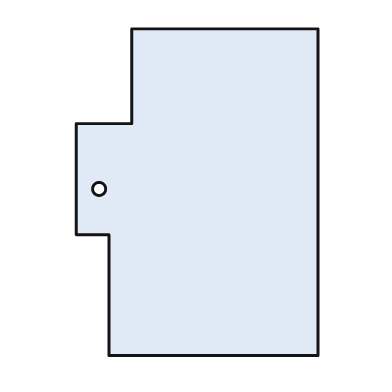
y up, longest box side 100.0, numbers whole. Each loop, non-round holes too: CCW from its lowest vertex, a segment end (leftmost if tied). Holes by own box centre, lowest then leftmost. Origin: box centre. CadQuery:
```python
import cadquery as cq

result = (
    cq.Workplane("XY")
    .moveTo(-27.0, -50.0)
    .lineTo(37.0, -50.0)
    .lineTo(37.0, 50.0)
    .lineTo(-20.0, 50.0)
    .lineTo(-20.0, 21.0)
    .lineTo(-37.0, 21.0)
    .lineTo(-37.0, -13.0)
    .lineTo(-27.0, -13.0)
    .close()
    .moveTo(-30.0, 1.0)
    .circle(2.0)
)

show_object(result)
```